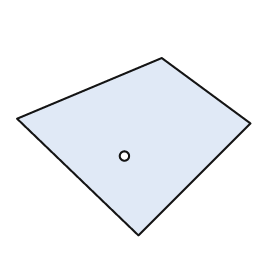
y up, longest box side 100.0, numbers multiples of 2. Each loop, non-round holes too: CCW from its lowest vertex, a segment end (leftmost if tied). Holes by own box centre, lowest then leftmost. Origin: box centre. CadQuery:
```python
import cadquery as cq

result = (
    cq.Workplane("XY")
    .moveTo(2.0, -38.0)
    .lineTo(50.0, 10.0)
    .lineTo(12.0, 38.0)
    .lineTo(-50.0, 12.0)
    .close()
    .moveTo(-4.0, -4.0)
    .circle(2.0)
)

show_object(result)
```